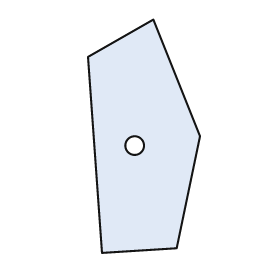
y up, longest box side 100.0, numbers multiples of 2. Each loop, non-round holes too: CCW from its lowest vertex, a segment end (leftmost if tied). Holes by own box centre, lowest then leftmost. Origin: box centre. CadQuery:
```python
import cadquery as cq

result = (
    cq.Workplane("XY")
    .moveTo(-18.0, -50.0)
    .lineTo(14.0, -48.0)
    .lineTo(24.0, 0.0)
    .lineTo(4.0, 50.0)
    .lineTo(-24.0, 34.0)
    .close()
    .moveTo(-4.0, -4.0)
    .circle(4.0)
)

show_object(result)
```